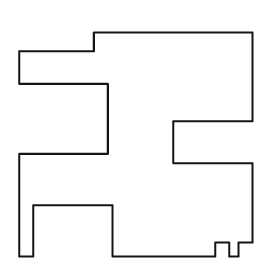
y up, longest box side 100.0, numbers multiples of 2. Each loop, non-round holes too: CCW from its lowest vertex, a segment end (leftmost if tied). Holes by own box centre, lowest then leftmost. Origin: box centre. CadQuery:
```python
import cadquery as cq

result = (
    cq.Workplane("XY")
    .moveTo(-50.0, -48.0)
    .lineTo(-44.0, -48.0)
    .lineTo(-44.0, -26.0)
    .lineTo(-10.0, -26.0)
    .lineTo(-10.0, -48.0)
    .lineTo(34.0, -48.0)
    .lineTo(34.0, -42.0)
    .lineTo(40.0, -42.0)
    .lineTo(40.0, -48.0)
    .lineTo(44.0, -48.0)
    .lineTo(44.0, -42.0)
    .lineTo(50.0, -42.0)
    .lineTo(50.0, -8.0)
    .lineTo(16.0, -8.0)
    .lineTo(16.0, 10.0)
    .lineTo(50.0, 10.0)
    .lineTo(50.0, 48.0)
    .lineTo(-18.0, 48.0)
    .lineTo(-18.0, 40.0)
    .lineTo(-50.0, 40.0)
    .lineTo(-50.0, 26.0)
    .lineTo(-12.0, 26.0)
    .lineTo(-12.0, -4.0)
    .lineTo(-50.0, -4.0)
    .close()
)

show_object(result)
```